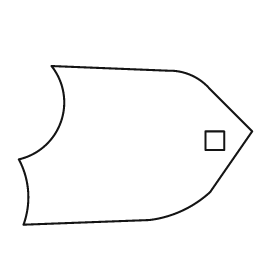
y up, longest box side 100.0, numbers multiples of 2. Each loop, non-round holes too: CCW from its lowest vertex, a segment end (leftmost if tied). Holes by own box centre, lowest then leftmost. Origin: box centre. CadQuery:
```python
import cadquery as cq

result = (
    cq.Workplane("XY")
    .moveTo(-48.0, -34.0)
    .lineTo(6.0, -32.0)
    .threePointArc((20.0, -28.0), (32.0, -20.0))
    .lineTo(50.0, 6.0)
    .lineTo(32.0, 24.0)
    .threePointArc((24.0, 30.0), (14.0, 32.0))
    .lineTo(-36.0, 34.0)
    .threePointArc((-32.0, 10.0), (-50.0, -6.0))
    .threePointArc((-46.0, -20.0), (-48.0, -34.0))
    .close()
    .moveTo(30.0, -2.0)
    .lineTo(38.0, -2.0)
    .lineTo(38.0, 6.0)
    .lineTo(30.0, 6.0)
    .close()
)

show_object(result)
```